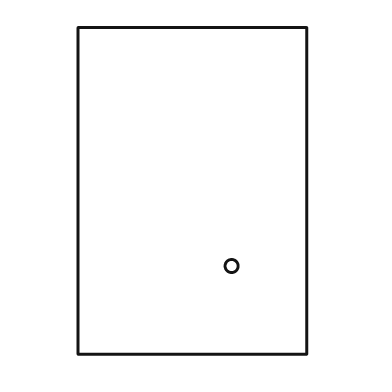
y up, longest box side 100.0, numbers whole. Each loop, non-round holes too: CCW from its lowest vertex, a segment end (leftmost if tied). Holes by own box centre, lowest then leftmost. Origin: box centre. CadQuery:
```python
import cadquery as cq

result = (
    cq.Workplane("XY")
    .moveTo(-35.0, -50.0)
    .lineTo(35.0, -50.0)
    .lineTo(35.0, 50.0)
    .lineTo(-35.0, 50.0)
    .close()
    .moveTo(12.0, -23.0)
    .circle(2.0)
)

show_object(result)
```